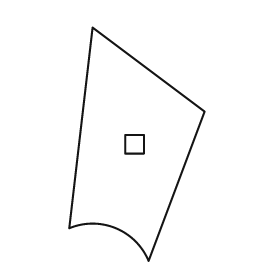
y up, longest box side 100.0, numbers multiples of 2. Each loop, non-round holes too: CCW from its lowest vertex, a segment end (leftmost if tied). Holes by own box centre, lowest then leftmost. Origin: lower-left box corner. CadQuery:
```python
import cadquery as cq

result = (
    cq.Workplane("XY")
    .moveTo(34.0, 0.0)
    .lineTo(58.0, 64.0)
    .lineTo(10.0, 100.0)
    .lineTo(0.0, 14.0)
    .threePointArc((20.0, 14.0), (34.0, 0.0))
    .close()
    .moveTo(24.0, 46.0)
    .lineTo(32.0, 46.0)
    .lineTo(32.0, 54.0)
    .lineTo(24.0, 54.0)
    .close()
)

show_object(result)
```